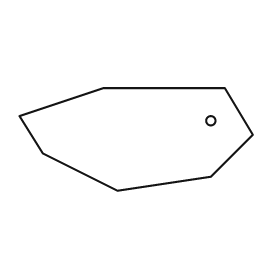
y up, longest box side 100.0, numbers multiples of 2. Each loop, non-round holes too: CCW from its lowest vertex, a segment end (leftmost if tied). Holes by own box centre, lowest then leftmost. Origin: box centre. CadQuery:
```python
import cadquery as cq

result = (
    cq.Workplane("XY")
    .moveTo(-8.0, -22.0)
    .lineTo(32.0, -16.0)
    .lineTo(50.0, 2.0)
    .lineTo(38.0, 22.0)
    .lineTo(-14.0, 22.0)
    .lineTo(-50.0, 10.0)
    .lineTo(-40.0, -6.0)
    .close()
    .moveTo(32.0, 8.0)
    .circle(2.0)
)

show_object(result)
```